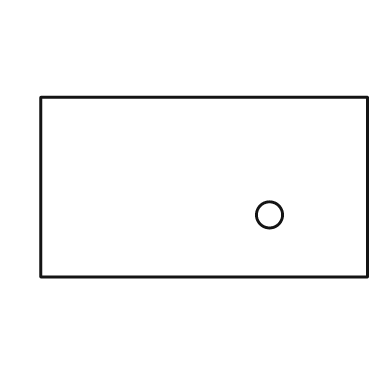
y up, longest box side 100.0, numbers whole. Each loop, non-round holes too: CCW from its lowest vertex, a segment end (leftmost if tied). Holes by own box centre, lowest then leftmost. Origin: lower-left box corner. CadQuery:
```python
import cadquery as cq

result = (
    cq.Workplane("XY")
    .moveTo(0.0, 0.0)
    .lineTo(100.0, 0.0)
    .lineTo(100.0, 55.0)
    .lineTo(0.0, 55.0)
    .close()
    .moveTo(70.0, 19.0)
    .circle(4.0)
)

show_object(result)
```